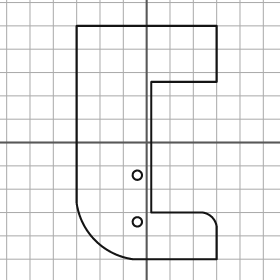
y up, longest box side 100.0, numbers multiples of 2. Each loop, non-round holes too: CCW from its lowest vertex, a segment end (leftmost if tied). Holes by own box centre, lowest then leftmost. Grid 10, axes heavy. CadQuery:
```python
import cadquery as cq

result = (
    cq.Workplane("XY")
    .moveTo(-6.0, -50.0)
    .lineTo(30.0, -50.0)
    .lineTo(30.0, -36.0)
    .threePointArc((28.0, -32.0), (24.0, -30.0))
    .lineTo(2.0, -30.0)
    .lineTo(2.0, 26.0)
    .lineTo(30.0, 26.0)
    .lineTo(30.0, 50.0)
    .lineTo(-30.0, 50.0)
    .lineTo(-30.0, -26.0)
    .threePointArc((-22.0, -42.0), (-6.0, -50.0))
    .close()
    .moveTo(-4.0, -34.0)
    .circle(2.0)
    .moveTo(-4.0, -14.0)
    .circle(2.0)
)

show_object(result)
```